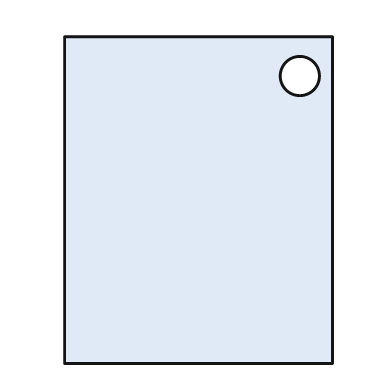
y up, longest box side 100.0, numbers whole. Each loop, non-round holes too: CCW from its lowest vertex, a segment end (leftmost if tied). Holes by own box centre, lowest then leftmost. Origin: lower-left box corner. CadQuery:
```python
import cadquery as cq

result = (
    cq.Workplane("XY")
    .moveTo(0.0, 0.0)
    .lineTo(82.0, 0.0)
    .lineTo(82.0, 100.0)
    .lineTo(0.0, 100.0)
    .close()
    .moveTo(72.0, 88.0)
    .circle(6.0)
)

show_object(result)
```